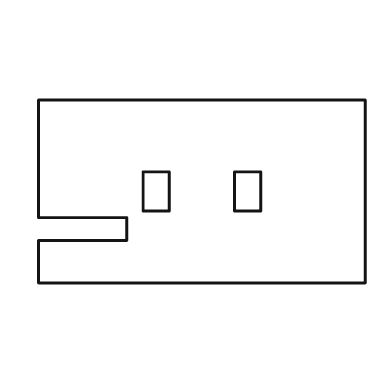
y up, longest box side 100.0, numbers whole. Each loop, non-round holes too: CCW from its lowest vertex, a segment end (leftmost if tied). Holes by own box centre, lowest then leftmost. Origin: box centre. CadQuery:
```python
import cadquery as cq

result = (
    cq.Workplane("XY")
    .moveTo(-50.0, -28.0)
    .lineTo(50.0, -28.0)
    .lineTo(50.0, 28.0)
    .lineTo(-50.0, 28.0)
    .lineTo(-50.0, -8.0)
    .lineTo(-23.0, -8.0)
    .lineTo(-23.0, -15.0)
    .lineTo(-50.0, -15.0)
    .close()
    .moveTo(-18.0, -6.0)
    .lineTo(-10.0, -6.0)
    .lineTo(-10.0, 6.0)
    .lineTo(-18.0, 6.0)
    .close()
    .moveTo(10.0, -6.0)
    .lineTo(18.0, -6.0)
    .lineTo(18.0, 6.0)
    .lineTo(10.0, 6.0)
    .close()
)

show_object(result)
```